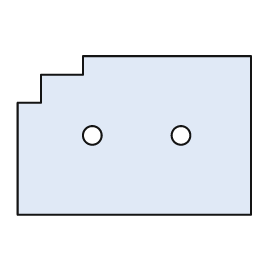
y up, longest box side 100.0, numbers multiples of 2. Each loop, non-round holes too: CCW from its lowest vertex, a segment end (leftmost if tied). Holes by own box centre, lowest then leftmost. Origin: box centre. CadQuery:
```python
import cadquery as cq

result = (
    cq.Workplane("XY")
    .moveTo(-50.0, -34.0)
    .lineTo(50.0, -34.0)
    .lineTo(50.0, 34.0)
    .lineTo(-22.0, 34.0)
    .lineTo(-22.0, 26.0)
    .lineTo(-40.0, 26.0)
    .lineTo(-40.0, 14.0)
    .lineTo(-50.0, 14.0)
    .close()
    .moveTo(-18.0, 0.0)
    .circle(4.0)
    .moveTo(20.0, 0.0)
    .circle(4.0)
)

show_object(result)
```